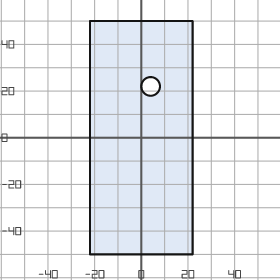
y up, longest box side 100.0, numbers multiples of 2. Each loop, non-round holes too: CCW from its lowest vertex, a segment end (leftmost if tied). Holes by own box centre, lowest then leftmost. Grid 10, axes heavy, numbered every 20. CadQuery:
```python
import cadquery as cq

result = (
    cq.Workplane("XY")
    .moveTo(-22.0, -50.0)
    .lineTo(22.0, -50.0)
    .lineTo(22.0, 50.0)
    .lineTo(-22.0, 50.0)
    .close()
    .moveTo(4.0, 22.0)
    .circle(4.0)
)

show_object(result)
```